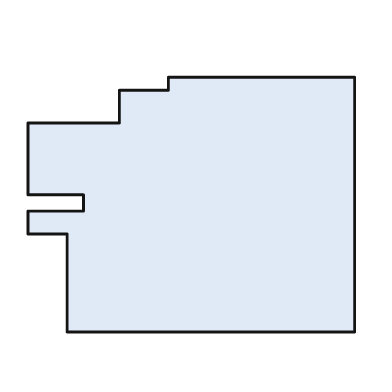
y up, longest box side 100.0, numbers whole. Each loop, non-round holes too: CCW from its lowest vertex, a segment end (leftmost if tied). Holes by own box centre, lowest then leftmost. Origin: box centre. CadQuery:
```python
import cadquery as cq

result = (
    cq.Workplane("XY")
    .moveTo(-38.0, -39.0)
    .lineTo(50.0, -39.0)
    .lineTo(50.0, 39.0)
    .lineTo(-7.0, 39.0)
    .lineTo(-7.0, 35.0)
    .lineTo(-22.0, 35.0)
    .lineTo(-22.0, 25.0)
    .lineTo(-50.0, 25.0)
    .lineTo(-50.0, 3.0)
    .lineTo(-33.0, 3.0)
    .lineTo(-33.0, -2.0)
    .lineTo(-50.0, -2.0)
    .lineTo(-50.0, -9.0)
    .lineTo(-38.0, -9.0)
    .close()
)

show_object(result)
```